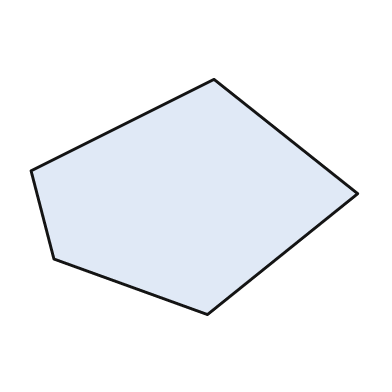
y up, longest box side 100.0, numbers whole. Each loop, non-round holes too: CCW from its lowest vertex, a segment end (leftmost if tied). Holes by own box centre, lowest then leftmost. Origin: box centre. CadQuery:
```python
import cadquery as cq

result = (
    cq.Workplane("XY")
    .moveTo(4.0, -36.0)
    .lineTo(50.0, 1.0)
    .lineTo(6.0, 36.0)
    .lineTo(-50.0, 8.0)
    .lineTo(-43.0, -19.0)
    .close()
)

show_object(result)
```